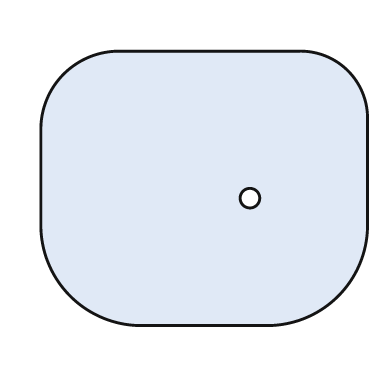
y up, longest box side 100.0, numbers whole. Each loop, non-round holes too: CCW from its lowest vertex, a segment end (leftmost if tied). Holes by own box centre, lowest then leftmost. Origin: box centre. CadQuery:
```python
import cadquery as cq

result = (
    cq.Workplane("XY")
    .moveTo(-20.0, -42.0)
    .lineTo(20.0, -42.0)
    .threePointArc((41.0, -33.0), (50.0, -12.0))
    .lineTo(50.0, 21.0)
    .threePointArc((44.0, 36.0), (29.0, 42.0))
    .lineTo(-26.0, 42.0)
    .threePointArc((-43.0, 35.0), (-50.0, 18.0))
    .lineTo(-50.0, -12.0)
    .threePointArc((-41.0, -33.0), (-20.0, -42.0))
    .close()
    .moveTo(14.0, -3.0)
    .circle(3.0)
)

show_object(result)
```